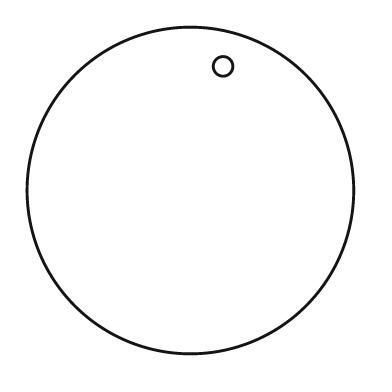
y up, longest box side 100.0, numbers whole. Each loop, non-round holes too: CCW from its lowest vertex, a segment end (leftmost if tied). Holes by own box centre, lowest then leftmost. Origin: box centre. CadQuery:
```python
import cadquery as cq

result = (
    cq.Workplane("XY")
    .moveTo(0.0, 0.0)
    .circle(50.0)
    .moveTo(10.0, 38.0)
    .circle(3.0)
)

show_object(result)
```